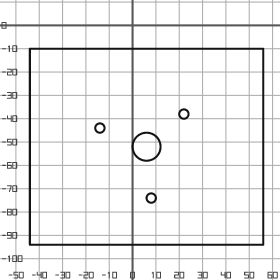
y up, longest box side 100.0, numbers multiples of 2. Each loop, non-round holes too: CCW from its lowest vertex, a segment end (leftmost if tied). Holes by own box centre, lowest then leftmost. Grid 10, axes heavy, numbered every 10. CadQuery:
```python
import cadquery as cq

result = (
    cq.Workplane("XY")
    .moveTo(-44.0, -94.0)
    .lineTo(56.0, -94.0)
    .lineTo(56.0, -10.0)
    .lineTo(-44.0, -10.0)
    .close()
    .moveTo(8.0, -74.0)
    .circle(2.0)
    .moveTo(6.0, -52.0)
    .circle(6.0)
    .moveTo(-14.0, -44.0)
    .circle(2.0)
    .moveTo(22.0, -38.0)
    .circle(2.0)
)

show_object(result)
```